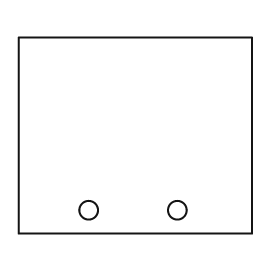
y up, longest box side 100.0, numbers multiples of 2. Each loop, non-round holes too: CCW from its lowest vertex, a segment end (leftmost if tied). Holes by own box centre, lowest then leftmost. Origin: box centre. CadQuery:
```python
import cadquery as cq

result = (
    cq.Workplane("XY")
    .moveTo(-50.0, -42.0)
    .lineTo(50.0, -42.0)
    .lineTo(50.0, 42.0)
    .lineTo(-50.0, 42.0)
    .close()
    .moveTo(-20.0, -32.0)
    .circle(4.0)
    .moveTo(18.0, -32.0)
    .circle(4.0)
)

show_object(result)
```